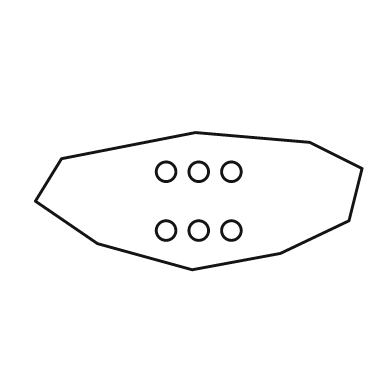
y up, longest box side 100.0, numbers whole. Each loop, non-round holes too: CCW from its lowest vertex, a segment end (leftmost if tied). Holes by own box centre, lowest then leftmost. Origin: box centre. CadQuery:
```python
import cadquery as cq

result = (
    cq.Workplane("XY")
    .moveTo(-2.0, -21.0)
    .lineTo(25.0, -16.0)
    .lineTo(46.0, -6.0)
    .lineTo(50.0, 10.0)
    .lineTo(34.0, 18.0)
    .lineTo(-1.0, 21.0)
    .lineTo(-42.0, 13.0)
    .lineTo(-50.0, 0.0)
    .lineTo(-31.0, -13.0)
    .close()
    .moveTo(-10.0, -9.0)
    .circle(3.0)
    .moveTo(0.0, -9.0)
    .circle(3.0)
    .moveTo(10.0, -9.0)
    .circle(3.0)
    .moveTo(-10.0, 9.0)
    .circle(3.0)
    .moveTo(0.0, 9.0)
    .circle(3.0)
    .moveTo(10.0, 9.0)
    .circle(3.0)
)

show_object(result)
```